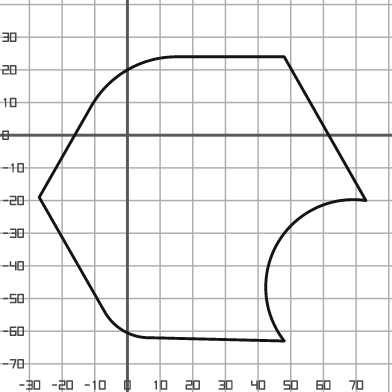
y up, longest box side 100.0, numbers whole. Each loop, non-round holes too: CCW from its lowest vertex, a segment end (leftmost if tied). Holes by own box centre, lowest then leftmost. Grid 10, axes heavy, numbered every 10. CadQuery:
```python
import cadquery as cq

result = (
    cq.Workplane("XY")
    .moveTo(48.0, -63.0)
    .threePointArc((46.0, -33.0), (73.0, -20.0))
    .lineTo(48.0, 24.0)
    .lineTo(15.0, 24.0)
    .threePointArc((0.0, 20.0), (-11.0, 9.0))
    .lineTo(-27.0, -19.0)
    .lineTo(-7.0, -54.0)
    .threePointArc((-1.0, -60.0), (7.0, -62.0))
    .close()
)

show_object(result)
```